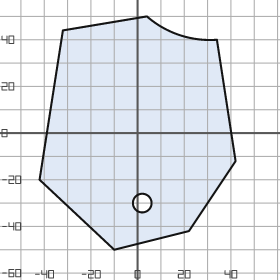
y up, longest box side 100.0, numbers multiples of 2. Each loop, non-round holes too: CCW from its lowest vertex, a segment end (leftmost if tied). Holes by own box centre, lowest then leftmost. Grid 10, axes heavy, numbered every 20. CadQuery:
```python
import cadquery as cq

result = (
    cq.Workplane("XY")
    .moveTo(-10.0, -50.0)
    .lineTo(22.0, -42.0)
    .lineTo(42.0, -12.0)
    .lineTo(34.0, 40.0)
    .threePointArc((18.0, 42.0), (4.0, 50.0))
    .lineTo(-32.0, 44.0)
    .lineTo(-42.0, -20.0)
    .close()
    .moveTo(2.0, -30.0)
    .circle(4.0)
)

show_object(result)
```